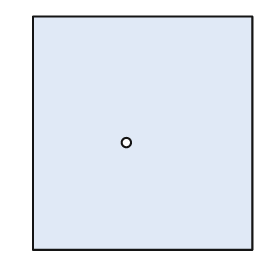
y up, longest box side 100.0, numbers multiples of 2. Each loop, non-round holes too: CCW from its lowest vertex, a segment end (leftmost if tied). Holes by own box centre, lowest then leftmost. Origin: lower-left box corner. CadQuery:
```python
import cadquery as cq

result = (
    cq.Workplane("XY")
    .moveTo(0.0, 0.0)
    .lineTo(94.0, 0.0)
    .lineTo(94.0, 100.0)
    .lineTo(0.0, 100.0)
    .close()
    .moveTo(40.0, 46.0)
    .circle(2.0)
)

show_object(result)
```